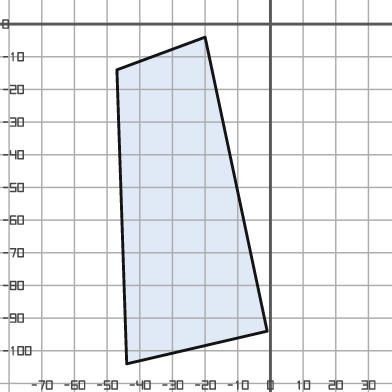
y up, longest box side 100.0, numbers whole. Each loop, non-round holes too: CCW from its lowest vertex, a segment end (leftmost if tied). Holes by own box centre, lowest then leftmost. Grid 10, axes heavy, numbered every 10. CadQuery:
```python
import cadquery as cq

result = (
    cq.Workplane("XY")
    .moveTo(-44.0, -104.0)
    .lineTo(-1.0, -94.0)
    .lineTo(-20.0, -4.0)
    .lineTo(-47.0, -14.0)
    .close()
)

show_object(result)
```